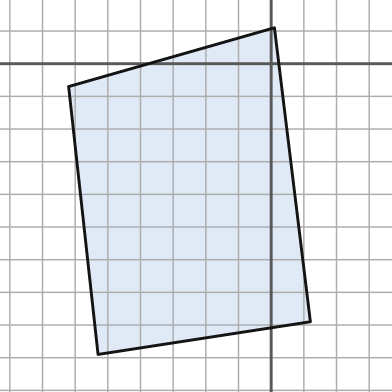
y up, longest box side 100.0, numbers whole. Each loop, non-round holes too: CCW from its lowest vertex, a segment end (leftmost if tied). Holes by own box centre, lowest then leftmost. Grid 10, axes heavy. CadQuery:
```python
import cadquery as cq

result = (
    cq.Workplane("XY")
    .moveTo(-53.0, -89.0)
    .lineTo(12.0, -79.0)
    .lineTo(1.0, 11.0)
    .lineTo(-62.0, -7.0)
    .close()
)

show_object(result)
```